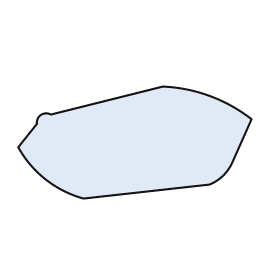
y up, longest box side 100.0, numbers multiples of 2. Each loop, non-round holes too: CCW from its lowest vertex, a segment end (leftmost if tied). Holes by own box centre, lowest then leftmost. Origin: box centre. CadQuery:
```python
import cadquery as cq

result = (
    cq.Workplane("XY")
    .moveTo(-22.0, -24.0)
    .lineTo(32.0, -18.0)
    .threePointArc((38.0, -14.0), (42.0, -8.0))
    .lineTo(50.0, 10.0)
    .threePointArc((32.0, 20.0), (12.0, 24.0))
    .lineTo(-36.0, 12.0)
    .threePointArc((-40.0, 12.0), (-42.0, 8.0))
    .lineTo(-50.0, -2.0)
    .threePointArc((-38.0, -16.0), (-22.0, -24.0))
    .close()
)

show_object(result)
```